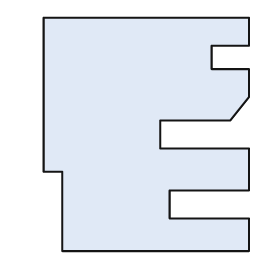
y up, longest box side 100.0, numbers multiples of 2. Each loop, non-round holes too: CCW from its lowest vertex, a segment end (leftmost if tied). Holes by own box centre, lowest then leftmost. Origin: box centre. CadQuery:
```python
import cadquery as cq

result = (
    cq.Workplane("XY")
    .moveTo(-36.0, -50.0)
    .lineTo(44.0, -50.0)
    .lineTo(44.0, -36.0)
    .lineTo(10.0, -36.0)
    .lineTo(10.0, -24.0)
    .lineTo(44.0, -24.0)
    .lineTo(44.0, -6.0)
    .lineTo(6.0, -6.0)
    .lineTo(6.0, 6.0)
    .lineTo(36.0, 6.0)
    .lineTo(44.0, 16.0)
    .lineTo(44.0, 28.0)
    .lineTo(28.0, 28.0)
    .lineTo(28.0, 38.0)
    .lineTo(44.0, 38.0)
    .lineTo(44.0, 50.0)
    .lineTo(-44.0, 50.0)
    .lineTo(-44.0, -16.0)
    .lineTo(-36.0, -16.0)
    .close()
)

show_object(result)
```